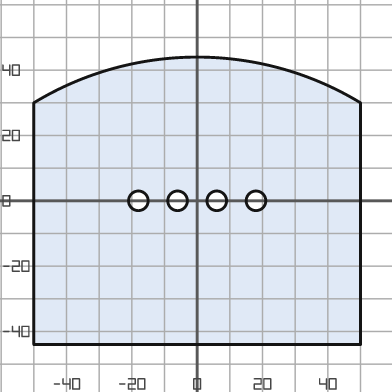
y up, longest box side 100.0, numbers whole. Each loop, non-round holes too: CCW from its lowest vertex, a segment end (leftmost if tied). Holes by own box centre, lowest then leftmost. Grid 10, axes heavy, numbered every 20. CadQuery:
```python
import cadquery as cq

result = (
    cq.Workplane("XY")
    .moveTo(-50.0, -44.0)
    .lineTo(50.0, -44.0)
    .lineTo(50.0, 30.0)
    .threePointArc((0.0, 44.0), (-50.0, 30.0))
    .close()
    .moveTo(-18.0, 0.0)
    .circle(3.0)
    .moveTo(-6.0, 0.0)
    .circle(3.0)
    .moveTo(6.0, 0.0)
    .circle(3.0)
    .moveTo(18.0, 0.0)
    .circle(3.0)
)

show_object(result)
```